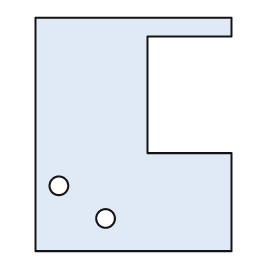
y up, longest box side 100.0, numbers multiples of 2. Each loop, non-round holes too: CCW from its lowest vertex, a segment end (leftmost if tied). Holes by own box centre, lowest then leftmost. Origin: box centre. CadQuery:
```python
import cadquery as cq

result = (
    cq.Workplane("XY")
    .moveTo(-42.0, -50.0)
    .lineTo(42.0, -50.0)
    .lineTo(42.0, -8.0)
    .lineTo(6.0, -8.0)
    .lineTo(6.0, 42.0)
    .lineTo(42.0, 42.0)
    .lineTo(42.0, 50.0)
    .lineTo(-42.0, 50.0)
    .close()
    .moveTo(-12.0, -36.0)
    .circle(4.0)
    .moveTo(-32.0, -22.0)
    .circle(4.0)
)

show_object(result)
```